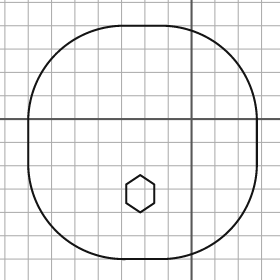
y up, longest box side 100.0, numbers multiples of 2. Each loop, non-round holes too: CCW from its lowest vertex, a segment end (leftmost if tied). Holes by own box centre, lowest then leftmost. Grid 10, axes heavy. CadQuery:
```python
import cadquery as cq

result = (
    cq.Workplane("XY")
    .moveTo(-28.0, -60.0)
    .lineTo(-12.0, -60.0)
    .threePointArc((16.0, -48.0), (28.0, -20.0))
    .lineTo(28.0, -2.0)
    .threePointArc((16.0, 28.0), (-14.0, 40.0))
    .lineTo(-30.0, 40.0)
    .threePointArc((-58.0, 28.0), (-70.0, 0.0))
    .lineTo(-70.0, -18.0)
    .threePointArc((-58.0, -48.0), (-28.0, -60.0))
    .close()
    .moveTo(-22.0, -40.0)
    .lineTo(-16.0, -36.0)
    .lineTo(-16.0, -28.0)
    .lineTo(-22.0, -24.0)
    .lineTo(-28.0, -28.0)
    .lineTo(-28.0, -36.0)
    .close()
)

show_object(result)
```